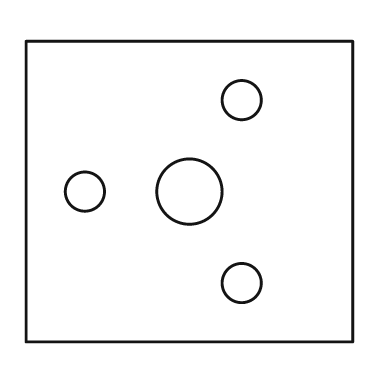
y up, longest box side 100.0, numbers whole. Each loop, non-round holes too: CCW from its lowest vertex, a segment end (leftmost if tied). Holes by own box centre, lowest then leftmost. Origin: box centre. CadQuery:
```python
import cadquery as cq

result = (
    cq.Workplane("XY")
    .moveTo(-50.0, -46.0)
    .lineTo(50.0, -46.0)
    .lineTo(50.0, 46.0)
    .lineTo(-50.0, 46.0)
    .close()
    .moveTo(16.0, -28.0)
    .circle(6.0)
    .moveTo(-32.0, 0.0)
    .circle(6.0)
    .moveTo(0.0, 0.0)
    .circle(10.0)
    .moveTo(16.0, 28.0)
    .circle(6.0)
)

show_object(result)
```